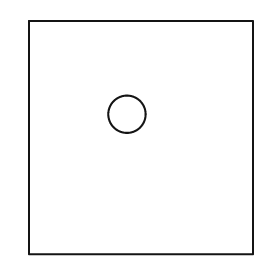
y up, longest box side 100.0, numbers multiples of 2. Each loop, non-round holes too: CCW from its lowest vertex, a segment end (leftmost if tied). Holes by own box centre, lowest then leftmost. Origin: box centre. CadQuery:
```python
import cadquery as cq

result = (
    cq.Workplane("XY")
    .moveTo(-48.0, -50.0)
    .lineTo(48.0, -50.0)
    .lineTo(48.0, 50.0)
    .lineTo(-48.0, 50.0)
    .close()
    .moveTo(-6.0, 10.0)
    .circle(8.0)
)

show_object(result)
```